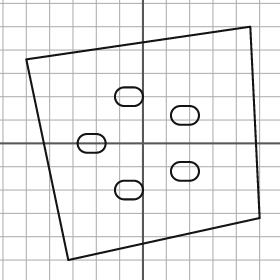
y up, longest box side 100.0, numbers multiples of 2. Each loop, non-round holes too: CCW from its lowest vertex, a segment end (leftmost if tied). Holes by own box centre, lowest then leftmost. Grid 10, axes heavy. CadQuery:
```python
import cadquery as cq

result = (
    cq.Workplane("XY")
    .moveTo(-32.0, -50.0)
    .lineTo(50.0, -32.0)
    .lineTo(46.0, 50.0)
    .lineTo(-50.0, 36.0)
    .close()
    .moveTo(-8.0, -24.0)
    .lineTo(-4.0, -24.0)
    .threePointArc((0.0, -20.0), (-4.0, -16.0))
    .lineTo(-8.0, -16.0)
    .threePointArc((-12.0, -20.0), (-8.0, -24.0))
    .close()
    .moveTo(16.0, -16.0)
    .lineTo(20.0, -16.0)
    .threePointArc((24.0, -12.0), (20.0, -8.0))
    .lineTo(16.0, -8.0)
    .threePointArc((12.0, -12.0), (16.0, -16.0))
    .close()
    .moveTo(-24.0, -4.0)
    .lineTo(-20.0, -4.0)
    .threePointArc((-16.0, 0.0), (-20.0, 4.0))
    .lineTo(-24.0, 4.0)
    .threePointArc((-28.0, 0.0), (-24.0, -4.0))
    .close()
    .moveTo(16.0, 8.0)
    .lineTo(20.0, 8.0)
    .threePointArc((24.0, 12.0), (20.0, 16.0))
    .lineTo(16.0, 16.0)
    .threePointArc((12.0, 12.0), (16.0, 8.0))
    .close()
    .moveTo(-8.0, 16.0)
    .lineTo(-4.0, 16.0)
    .threePointArc((0.0, 20.0), (-4.0, 24.0))
    .lineTo(-8.0, 24.0)
    .threePointArc((-12.0, 20.0), (-8.0, 16.0))
    .close()
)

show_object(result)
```